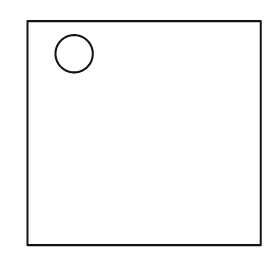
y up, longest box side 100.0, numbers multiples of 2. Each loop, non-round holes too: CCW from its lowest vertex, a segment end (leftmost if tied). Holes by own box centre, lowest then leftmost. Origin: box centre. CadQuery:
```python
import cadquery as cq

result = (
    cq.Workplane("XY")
    .moveTo(-50.0, -48.0)
    .lineTo(50.0, -48.0)
    .lineTo(50.0, 48.0)
    .lineTo(-50.0, 48.0)
    .close()
    .moveTo(-30.0, 34.0)
    .circle(8.0)
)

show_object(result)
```